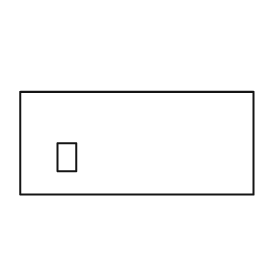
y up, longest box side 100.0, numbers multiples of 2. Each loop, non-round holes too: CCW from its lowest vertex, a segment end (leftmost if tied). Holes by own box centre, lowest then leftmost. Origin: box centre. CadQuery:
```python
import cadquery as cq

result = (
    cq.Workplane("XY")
    .moveTo(-50.0, -22.0)
    .lineTo(50.0, -22.0)
    .lineTo(50.0, 22.0)
    .lineTo(-50.0, 22.0)
    .close()
    .moveTo(-34.0, -12.0)
    .lineTo(-26.0, -12.0)
    .lineTo(-26.0, 0.0)
    .lineTo(-34.0, 0.0)
    .close()
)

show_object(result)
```